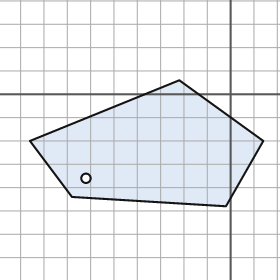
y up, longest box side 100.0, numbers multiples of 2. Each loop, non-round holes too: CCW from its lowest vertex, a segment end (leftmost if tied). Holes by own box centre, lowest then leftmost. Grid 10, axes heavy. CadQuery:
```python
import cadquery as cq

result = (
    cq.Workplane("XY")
    .moveTo(-2.0, -48.0)
    .lineTo(14.0, -20.0)
    .lineTo(-22.0, 6.0)
    .lineTo(-86.0, -20.0)
    .lineTo(-68.0, -44.0)
    .close()
    .moveTo(-62.0, -36.0)
    .circle(2.0)
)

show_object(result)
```